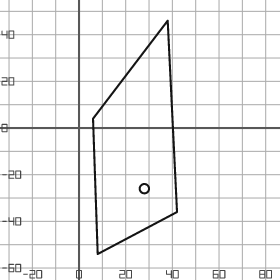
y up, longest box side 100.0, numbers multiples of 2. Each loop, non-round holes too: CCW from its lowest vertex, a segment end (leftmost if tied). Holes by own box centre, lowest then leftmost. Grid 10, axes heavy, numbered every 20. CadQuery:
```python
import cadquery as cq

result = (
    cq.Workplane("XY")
    .moveTo(8.0, -54.0)
    .lineTo(42.0, -36.0)
    .lineTo(38.0, 46.0)
    .lineTo(6.0, 4.0)
    .close()
    .moveTo(28.0, -26.0)
    .circle(2.0)
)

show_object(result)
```